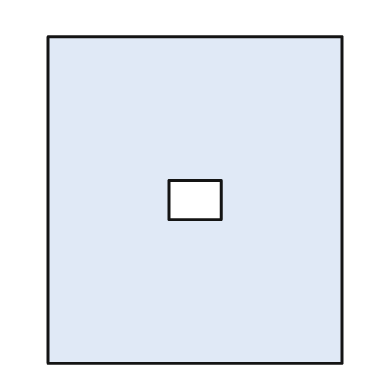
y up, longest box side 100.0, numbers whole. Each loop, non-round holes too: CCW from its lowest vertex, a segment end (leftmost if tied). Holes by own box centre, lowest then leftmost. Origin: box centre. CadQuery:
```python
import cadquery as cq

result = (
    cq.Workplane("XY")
    .moveTo(-45.0, -50.0)
    .lineTo(45.0, -50.0)
    .lineTo(45.0, 50.0)
    .lineTo(-45.0, 50.0)
    .close()
    .moveTo(-8.0, -6.0)
    .lineTo(8.0, -6.0)
    .lineTo(8.0, 6.0)
    .lineTo(-8.0, 6.0)
    .close()
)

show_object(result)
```